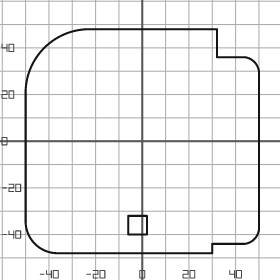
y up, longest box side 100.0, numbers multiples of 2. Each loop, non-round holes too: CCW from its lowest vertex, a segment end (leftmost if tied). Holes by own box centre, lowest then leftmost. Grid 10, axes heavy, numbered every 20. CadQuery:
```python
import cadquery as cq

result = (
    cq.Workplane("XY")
    .moveTo(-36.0, -48.0)
    .lineTo(30.0, -48.0)
    .lineTo(30.0, -44.0)
    .lineTo(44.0, -44.0)
    .threePointArc((48.0, -42.0), (50.0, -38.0))
    .lineTo(50.0, 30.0)
    .threePointArc((48.0, 34.0), (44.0, 36.0))
    .lineTo(32.0, 36.0)
    .lineTo(32.0, 48.0)
    .lineTo(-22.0, 48.0)
    .threePointArc((-42.0, 40.0), (-50.0, 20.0))
    .lineTo(-50.0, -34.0)
    .threePointArc((-46.0, -44.0), (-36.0, -48.0))
    .close()
    .moveTo(-6.0, -40.0)
    .lineTo(2.0, -40.0)
    .lineTo(2.0, -32.0)
    .lineTo(-6.0, -32.0)
    .close()
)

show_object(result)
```